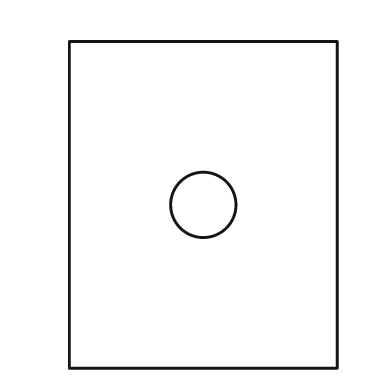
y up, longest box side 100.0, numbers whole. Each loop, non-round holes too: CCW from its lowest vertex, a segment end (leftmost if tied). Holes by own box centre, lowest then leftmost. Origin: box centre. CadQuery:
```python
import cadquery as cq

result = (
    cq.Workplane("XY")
    .moveTo(-41.0, -50.0)
    .lineTo(41.0, -50.0)
    .lineTo(41.0, 50.0)
    .lineTo(-41.0, 50.0)
    .close()
    .moveTo(0.0, 0.0)
    .circle(10.0)
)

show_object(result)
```